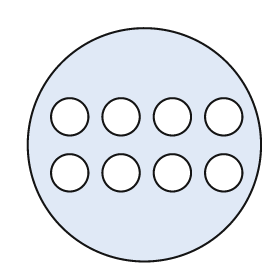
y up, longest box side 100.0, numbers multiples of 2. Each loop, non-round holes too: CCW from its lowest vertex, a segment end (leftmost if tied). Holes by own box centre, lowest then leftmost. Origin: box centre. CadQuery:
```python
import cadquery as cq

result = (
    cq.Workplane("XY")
    .moveTo(0.0, 0.0)
    .circle(50.0)
    .moveTo(-32.0, -12.0)
    .circle(8.0)
    .moveTo(-10.0, -12.0)
    .circle(8.0)
    .moveTo(12.0, -12.0)
    .circle(8.0)
    .moveTo(34.0, -12.0)
    .circle(8.0)
    .moveTo(-32.0, 12.0)
    .circle(8.0)
    .moveTo(-10.0, 12.0)
    .circle(8.0)
    .moveTo(12.0, 12.0)
    .circle(8.0)
    .moveTo(34.0, 12.0)
    .circle(8.0)
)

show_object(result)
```